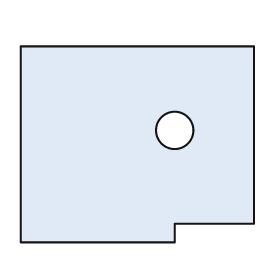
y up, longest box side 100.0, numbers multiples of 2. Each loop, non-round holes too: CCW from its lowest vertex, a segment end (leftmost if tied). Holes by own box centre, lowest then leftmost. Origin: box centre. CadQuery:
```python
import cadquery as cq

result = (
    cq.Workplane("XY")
    .moveTo(-50.0, -42.0)
    .lineTo(16.0, -42.0)
    .lineTo(16.0, -34.0)
    .lineTo(50.0, -34.0)
    .lineTo(50.0, 42.0)
    .lineTo(-50.0, 42.0)
    .close()
    .moveTo(16.0, 6.0)
    .circle(8.0)
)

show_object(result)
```